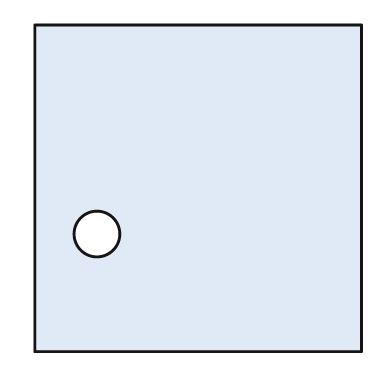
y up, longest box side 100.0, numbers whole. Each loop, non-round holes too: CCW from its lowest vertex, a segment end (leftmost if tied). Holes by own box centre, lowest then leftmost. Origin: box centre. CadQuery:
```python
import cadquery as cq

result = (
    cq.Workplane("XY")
    .moveTo(-50.0, -50.0)
    .lineTo(50.0, -50.0)
    .lineTo(50.0, 50.0)
    .lineTo(-50.0, 50.0)
    .close()
    .moveTo(-31.0, -14.0)
    .circle(7.0)
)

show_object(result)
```